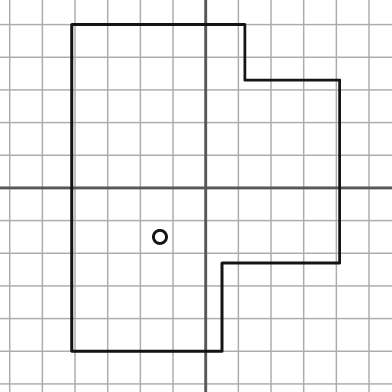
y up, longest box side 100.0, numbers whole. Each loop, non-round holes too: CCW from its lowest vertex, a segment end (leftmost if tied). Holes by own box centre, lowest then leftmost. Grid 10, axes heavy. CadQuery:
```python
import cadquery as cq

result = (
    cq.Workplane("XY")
    .moveTo(-41.0, -50.0)
    .lineTo(5.0, -50.0)
    .lineTo(5.0, -23.0)
    .lineTo(41.0, -23.0)
    .lineTo(41.0, 33.0)
    .lineTo(12.0, 33.0)
    .lineTo(12.0, 50.0)
    .lineTo(-41.0, 50.0)
    .close()
    .moveTo(-14.0, -15.0)
    .circle(2.0)
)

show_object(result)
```